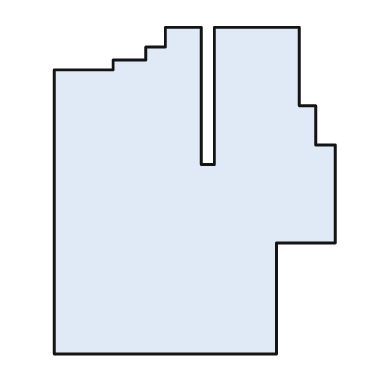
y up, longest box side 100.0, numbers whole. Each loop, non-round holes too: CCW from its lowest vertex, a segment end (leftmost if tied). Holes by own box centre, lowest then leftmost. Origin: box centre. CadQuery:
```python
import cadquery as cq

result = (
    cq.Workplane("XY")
    .moveTo(-43.0, -50.0)
    .lineTo(25.0, -50.0)
    .lineTo(25.0, -16.0)
    .lineTo(43.0, -16.0)
    .lineTo(43.0, 14.0)
    .lineTo(37.0, 14.0)
    .lineTo(37.0, 26.0)
    .lineTo(32.0, 26.0)
    .lineTo(32.0, 50.0)
    .lineTo(6.0, 50.0)
    .lineTo(6.0, 8.0)
    .lineTo(2.0, 8.0)
    .lineTo(2.0, 50.0)
    .lineTo(-9.0, 50.0)
    .lineTo(-9.0, 44.0)
    .lineTo(-15.0, 44.0)
    .lineTo(-15.0, 40.0)
    .lineTo(-25.0, 40.0)
    .lineTo(-25.0, 37.0)
    .lineTo(-43.0, 37.0)
    .close()
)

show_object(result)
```